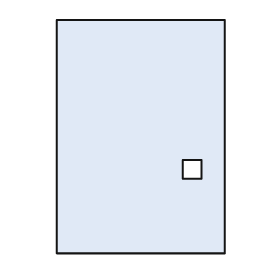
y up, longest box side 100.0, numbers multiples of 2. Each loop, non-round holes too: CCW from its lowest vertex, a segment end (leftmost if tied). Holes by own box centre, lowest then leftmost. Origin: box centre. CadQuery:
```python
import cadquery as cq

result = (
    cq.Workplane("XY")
    .moveTo(-36.0, -50.0)
    .lineTo(36.0, -50.0)
    .lineTo(36.0, 50.0)
    .lineTo(-36.0, 50.0)
    .close()
    .moveTo(18.0, -18.0)
    .lineTo(26.0, -18.0)
    .lineTo(26.0, -10.0)
    .lineTo(18.0, -10.0)
    .close()
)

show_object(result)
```